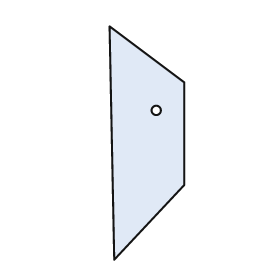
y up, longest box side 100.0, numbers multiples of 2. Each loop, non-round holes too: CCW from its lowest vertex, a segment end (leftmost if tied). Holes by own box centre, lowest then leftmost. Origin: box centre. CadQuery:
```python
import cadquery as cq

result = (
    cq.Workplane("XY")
    .moveTo(-14.0, -50.0)
    .lineTo(16.0, -18.0)
    .lineTo(16.0, 26.0)
    .lineTo(-16.0, 50.0)
    .close()
    .moveTo(4.0, 14.0)
    .circle(2.0)
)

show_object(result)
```